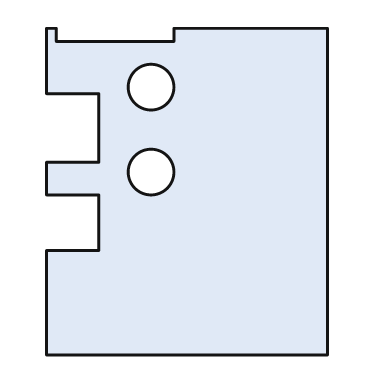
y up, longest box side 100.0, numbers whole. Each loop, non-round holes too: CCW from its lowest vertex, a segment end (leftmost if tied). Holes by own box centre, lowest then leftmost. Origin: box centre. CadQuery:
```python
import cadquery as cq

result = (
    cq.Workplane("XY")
    .moveTo(-43.0, -50.0)
    .lineTo(43.0, -50.0)
    .lineTo(43.0, 50.0)
    .lineTo(-4.0, 50.0)
    .lineTo(-4.0, 46.0)
    .lineTo(-40.0, 46.0)
    .lineTo(-40.0, 50.0)
    .lineTo(-43.0, 50.0)
    .lineTo(-43.0, 30.0)
    .lineTo(-27.0, 30.0)
    .lineTo(-27.0, 9.0)
    .lineTo(-43.0, 9.0)
    .lineTo(-43.0, -1.0)
    .lineTo(-27.0, -1.0)
    .lineTo(-27.0, -18.0)
    .lineTo(-43.0, -18.0)
    .close()
    .moveTo(-11.0, 6.0)
    .circle(7.0)
    .moveTo(-11.0, 32.0)
    .circle(7.0)
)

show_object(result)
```